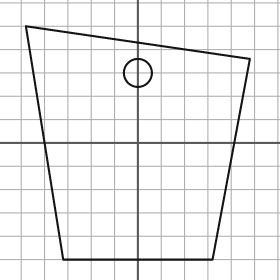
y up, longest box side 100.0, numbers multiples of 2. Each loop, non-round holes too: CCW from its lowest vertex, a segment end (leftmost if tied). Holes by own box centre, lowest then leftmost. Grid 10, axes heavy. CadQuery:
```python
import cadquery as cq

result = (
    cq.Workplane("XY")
    .moveTo(-32.0, -50.0)
    .lineTo(32.0, -50.0)
    .lineTo(48.0, 36.0)
    .lineTo(-48.0, 50.0)
    .close()
    .moveTo(0.0, 30.0)
    .circle(6.0)
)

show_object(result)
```